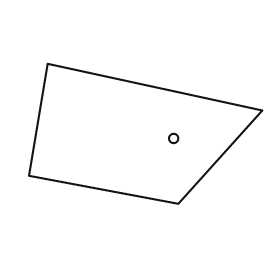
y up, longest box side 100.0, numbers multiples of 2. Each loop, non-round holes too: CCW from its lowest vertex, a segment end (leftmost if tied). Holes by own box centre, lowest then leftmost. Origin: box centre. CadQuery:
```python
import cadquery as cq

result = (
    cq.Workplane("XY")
    .moveTo(14.0, -30.0)
    .lineTo(50.0, 10.0)
    .lineTo(-42.0, 30.0)
    .lineTo(-50.0, -18.0)
    .close()
    .moveTo(12.0, -2.0)
    .circle(2.0)
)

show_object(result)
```